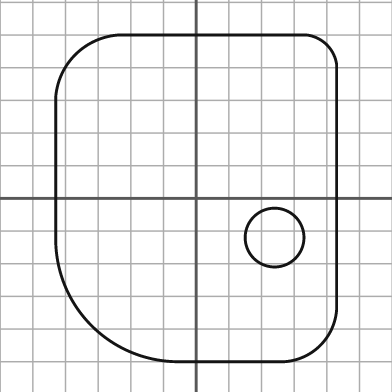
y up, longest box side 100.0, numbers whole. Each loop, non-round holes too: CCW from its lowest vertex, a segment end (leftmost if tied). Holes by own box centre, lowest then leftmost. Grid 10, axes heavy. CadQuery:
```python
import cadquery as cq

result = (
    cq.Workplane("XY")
    .moveTo(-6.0, -50.0)
    .lineTo(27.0, -50.0)
    .threePointArc((38.0, -45.0), (43.0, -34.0))
    .lineTo(43.0, 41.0)
    .threePointArc((40.0, 47.0), (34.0, 50.0))
    .lineTo(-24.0, 50.0)
    .threePointArc((-37.0, 44.0), (-43.0, 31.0))
    .lineTo(-43.0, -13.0)
    .threePointArc((-32.0, -39.0), (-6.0, -50.0))
    .close()
    .moveTo(24.0, -12.0)
    .circle(9.0)
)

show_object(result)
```